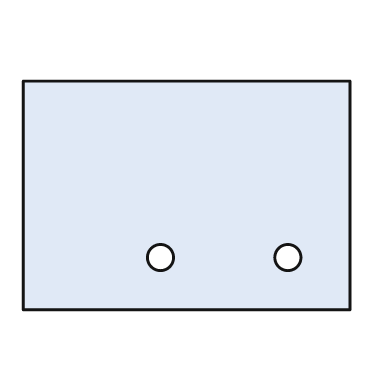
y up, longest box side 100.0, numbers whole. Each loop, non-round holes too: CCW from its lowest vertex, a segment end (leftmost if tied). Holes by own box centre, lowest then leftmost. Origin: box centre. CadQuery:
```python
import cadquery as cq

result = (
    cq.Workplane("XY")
    .moveTo(-50.0, -35.0)
    .lineTo(50.0, -35.0)
    .lineTo(50.0, 35.0)
    .lineTo(-50.0, 35.0)
    .close()
    .moveTo(-8.0, -19.0)
    .circle(4.0)
    .moveTo(31.0, -19.0)
    .circle(4.0)
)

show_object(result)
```